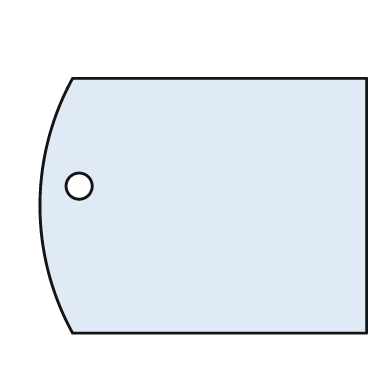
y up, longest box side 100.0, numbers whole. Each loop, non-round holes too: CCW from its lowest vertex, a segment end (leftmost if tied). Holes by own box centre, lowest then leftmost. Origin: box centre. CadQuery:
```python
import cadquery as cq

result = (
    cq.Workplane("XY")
    .moveTo(-40.0, -39.0)
    .lineTo(50.0, -39.0)
    .lineTo(50.0, 39.0)
    .lineTo(-40.0, 39.0)
    .threePointArc((-50.0, 0.0), (-40.0, -39.0))
    .close()
    .moveTo(-38.0, 6.0)
    .circle(4.0)
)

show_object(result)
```